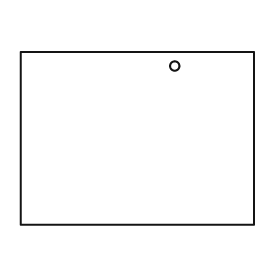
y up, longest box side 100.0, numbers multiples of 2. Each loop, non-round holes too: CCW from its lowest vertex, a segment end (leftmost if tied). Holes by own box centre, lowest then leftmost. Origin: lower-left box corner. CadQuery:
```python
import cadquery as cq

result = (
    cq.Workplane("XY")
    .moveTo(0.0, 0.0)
    .lineTo(100.0, 0.0)
    .lineTo(100.0, 74.0)
    .lineTo(0.0, 74.0)
    .close()
    .moveTo(66.0, 68.0)
    .circle(2.0)
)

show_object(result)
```